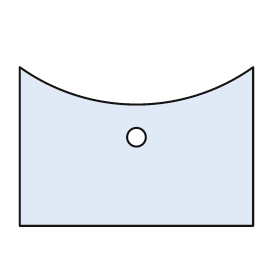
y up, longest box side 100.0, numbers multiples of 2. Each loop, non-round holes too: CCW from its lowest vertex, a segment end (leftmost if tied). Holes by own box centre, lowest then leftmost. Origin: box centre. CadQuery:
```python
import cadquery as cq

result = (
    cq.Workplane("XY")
    .moveTo(-50.0, -34.0)
    .lineTo(50.0, -34.0)
    .lineTo(50.0, 34.0)
    .threePointArc((0.0, 18.0), (-50.0, 34.0))
    .close()
    .moveTo(0.0, 4.0)
    .circle(4.0)
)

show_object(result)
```